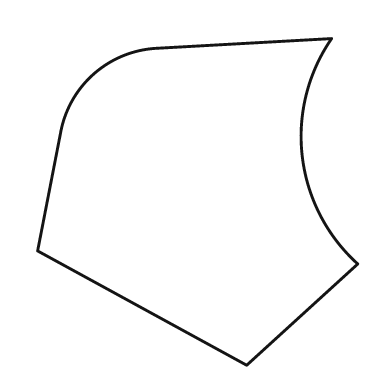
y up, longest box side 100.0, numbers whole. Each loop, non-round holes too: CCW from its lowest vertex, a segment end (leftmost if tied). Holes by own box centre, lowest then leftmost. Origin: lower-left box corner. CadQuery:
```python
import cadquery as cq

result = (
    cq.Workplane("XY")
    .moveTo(64.0, 0.0)
    .lineTo(98.0, 31.0)
    .threePointArc((81.0, 64.0), (90.0, 100.0))
    .lineTo(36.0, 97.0)
    .threePointArc((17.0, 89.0), (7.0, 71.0))
    .lineTo(0.0, 35.0)
    .close()
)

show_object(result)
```